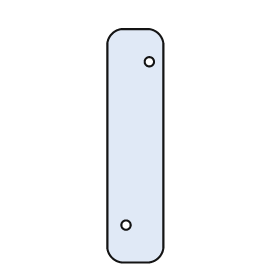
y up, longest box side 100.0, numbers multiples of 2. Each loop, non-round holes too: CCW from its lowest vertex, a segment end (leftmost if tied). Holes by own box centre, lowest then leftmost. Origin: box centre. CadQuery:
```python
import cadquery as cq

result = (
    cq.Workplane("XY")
    .moveTo(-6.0, -50.0)
    .lineTo(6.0, -50.0)
    .threePointArc((10.0, -48.0), (12.0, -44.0))
    .lineTo(12.0, 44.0)
    .threePointArc((10.0, 48.0), (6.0, 50.0))
    .lineTo(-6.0, 50.0)
    .threePointArc((-10.0, 48.0), (-12.0, 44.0))
    .lineTo(-12.0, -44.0)
    .threePointArc((-10.0, -48.0), (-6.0, -50.0))
    .close()
    .moveTo(-4.0, -34.0)
    .circle(2.0)
    .moveTo(6.0, 36.0)
    .circle(2.0)
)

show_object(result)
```